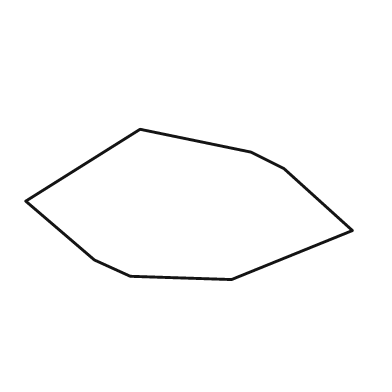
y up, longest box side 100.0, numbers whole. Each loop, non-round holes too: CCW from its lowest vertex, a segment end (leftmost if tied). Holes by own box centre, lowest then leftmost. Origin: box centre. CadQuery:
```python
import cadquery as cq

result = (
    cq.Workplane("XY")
    .moveTo(13.0, -23.0)
    .lineTo(50.0, -8.0)
    .lineTo(29.0, 11.0)
    .lineTo(19.0, 16.0)
    .lineTo(-15.0, 23.0)
    .lineTo(-50.0, 1.0)
    .lineTo(-29.0, -17.0)
    .lineTo(-18.0, -22.0)
    .close()
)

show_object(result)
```